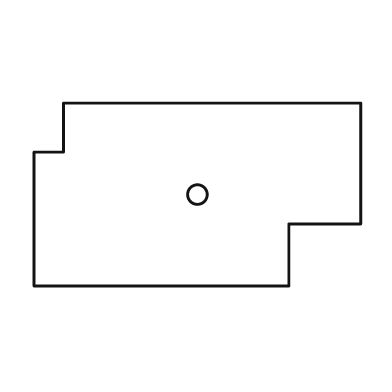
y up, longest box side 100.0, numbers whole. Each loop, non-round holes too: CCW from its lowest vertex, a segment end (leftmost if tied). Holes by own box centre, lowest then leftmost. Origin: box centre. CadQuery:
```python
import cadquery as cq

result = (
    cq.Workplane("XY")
    .moveTo(-50.0, -28.0)
    .lineTo(28.0, -28.0)
    .lineTo(28.0, -9.0)
    .lineTo(50.0, -9.0)
    .lineTo(50.0, 28.0)
    .lineTo(-41.0, 28.0)
    .lineTo(-41.0, 13.0)
    .lineTo(-50.0, 13.0)
    .close()
    .moveTo(0.0, 0.0)
    .circle(3.0)
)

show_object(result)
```